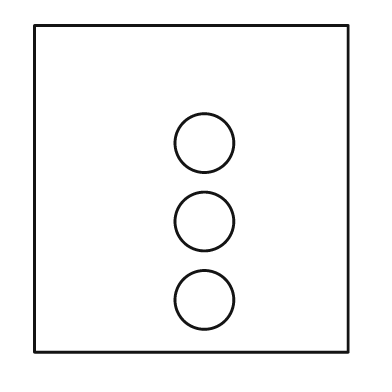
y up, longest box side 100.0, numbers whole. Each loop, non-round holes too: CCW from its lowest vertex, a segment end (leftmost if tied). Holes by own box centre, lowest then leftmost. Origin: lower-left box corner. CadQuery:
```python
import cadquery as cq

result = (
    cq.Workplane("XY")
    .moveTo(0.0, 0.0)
    .lineTo(96.0, 0.0)
    .lineTo(96.0, 100.0)
    .lineTo(0.0, 100.0)
    .close()
    .moveTo(52.0, 16.0)
    .circle(9.0)
    .moveTo(52.0, 40.0)
    .circle(9.0)
    .moveTo(52.0, 64.0)
    .circle(9.0)
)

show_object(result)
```